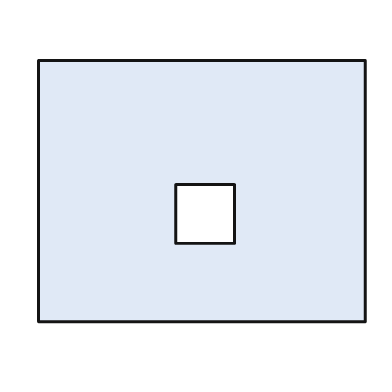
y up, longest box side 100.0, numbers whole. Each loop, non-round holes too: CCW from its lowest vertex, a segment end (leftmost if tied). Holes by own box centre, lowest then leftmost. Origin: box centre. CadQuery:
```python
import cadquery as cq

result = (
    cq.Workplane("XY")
    .moveTo(-50.0, -40.0)
    .lineTo(50.0, -40.0)
    .lineTo(50.0, 40.0)
    .lineTo(-50.0, 40.0)
    .close()
    .moveTo(-8.0, -16.0)
    .lineTo(10.0, -16.0)
    .lineTo(10.0, 2.0)
    .lineTo(-8.0, 2.0)
    .close()
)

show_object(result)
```